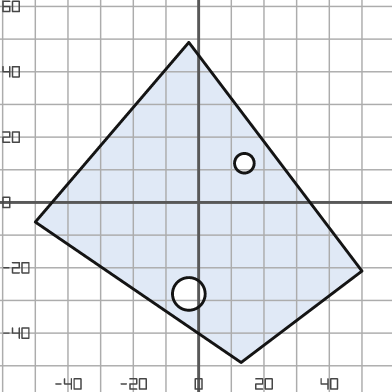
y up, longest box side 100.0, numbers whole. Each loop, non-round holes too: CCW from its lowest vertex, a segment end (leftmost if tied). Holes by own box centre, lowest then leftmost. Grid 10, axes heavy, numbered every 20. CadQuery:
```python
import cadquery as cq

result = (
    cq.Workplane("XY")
    .moveTo(13.0, -49.0)
    .lineTo(50.0, -21.0)
    .lineTo(-3.0, 49.0)
    .lineTo(-50.0, -6.0)
    .close()
    .moveTo(-3.0, -28.0)
    .circle(5.0)
    .moveTo(14.0, 12.0)
    .circle(3.0)
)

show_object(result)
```